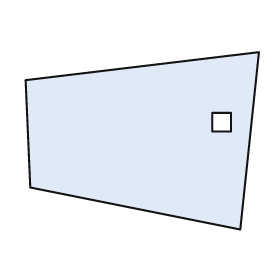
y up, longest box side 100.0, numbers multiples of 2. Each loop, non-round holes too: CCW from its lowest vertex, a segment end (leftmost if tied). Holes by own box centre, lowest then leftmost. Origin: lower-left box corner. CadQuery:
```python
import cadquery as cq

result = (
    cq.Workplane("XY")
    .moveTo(92.0, 0.0)
    .lineTo(100.0, 76.0)
    .lineTo(0.0, 64.0)
    .lineTo(2.0, 18.0)
    .close()
    .moveTo(80.0, 42.0)
    .lineTo(88.0, 42.0)
    .lineTo(88.0, 50.0)
    .lineTo(80.0, 50.0)
    .close()
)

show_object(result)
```